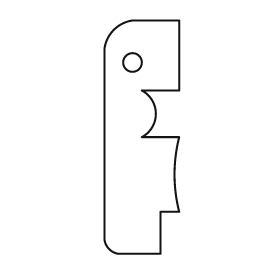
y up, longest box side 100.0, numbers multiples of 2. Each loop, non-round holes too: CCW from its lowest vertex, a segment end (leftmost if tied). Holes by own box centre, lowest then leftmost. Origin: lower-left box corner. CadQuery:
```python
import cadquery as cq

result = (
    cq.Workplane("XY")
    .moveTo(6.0, 0.0)
    .lineTo(24.0, 0.0)
    .lineTo(24.0, 18.0)
    .lineTo(32.0, 18.0)
    .threePointArc((30.0, 34.0), (32.0, 50.0))
    .lineTo(16.0, 50.0)
    .threePointArc((22.0, 60.0), (16.0, 70.0))
    .lineTo(32.0, 70.0)
    .lineTo(32.0, 100.0)
    .lineTo(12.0, 100.0)
    .threePointArc((4.0, 96.0), (0.0, 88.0))
    .lineTo(0.0, 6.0)
    .threePointArc((2.0, 2.0), (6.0, 0.0))
    .close()
    .moveTo(12.0, 82.0)
    .circle(4.0)
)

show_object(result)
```